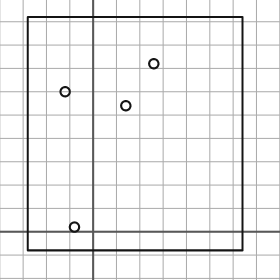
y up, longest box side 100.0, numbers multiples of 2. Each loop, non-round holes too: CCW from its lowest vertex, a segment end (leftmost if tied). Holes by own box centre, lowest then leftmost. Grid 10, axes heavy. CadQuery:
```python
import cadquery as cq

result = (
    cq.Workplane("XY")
    .moveTo(-28.0, -8.0)
    .lineTo(64.0, -8.0)
    .lineTo(64.0, 92.0)
    .lineTo(-28.0, 92.0)
    .close()
    .moveTo(-8.0, 2.0)
    .circle(2.0)
    .moveTo(14.0, 54.0)
    .circle(2.0)
    .moveTo(-12.0, 60.0)
    .circle(2.0)
    .moveTo(26.0, 72.0)
    .circle(2.0)
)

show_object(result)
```